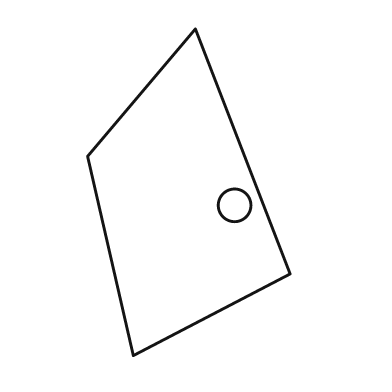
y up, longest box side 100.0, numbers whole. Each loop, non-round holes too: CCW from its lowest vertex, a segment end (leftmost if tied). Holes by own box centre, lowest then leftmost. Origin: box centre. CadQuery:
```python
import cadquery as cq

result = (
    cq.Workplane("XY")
    .moveTo(-17.0, -50.0)
    .lineTo(31.0, -25.0)
    .lineTo(2.0, 50.0)
    .lineTo(-31.0, 11.0)
    .close()
    .moveTo(14.0, -4.0)
    .circle(5.0)
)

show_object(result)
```